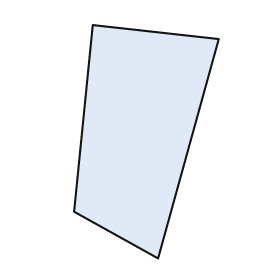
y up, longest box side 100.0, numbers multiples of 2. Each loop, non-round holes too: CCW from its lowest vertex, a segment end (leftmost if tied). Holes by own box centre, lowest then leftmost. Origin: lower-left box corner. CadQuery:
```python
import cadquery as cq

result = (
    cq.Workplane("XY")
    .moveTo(36.0, 0.0)
    .lineTo(62.0, 94.0)
    .lineTo(8.0, 100.0)
    .lineTo(0.0, 20.0)
    .close()
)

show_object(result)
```